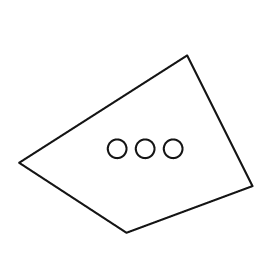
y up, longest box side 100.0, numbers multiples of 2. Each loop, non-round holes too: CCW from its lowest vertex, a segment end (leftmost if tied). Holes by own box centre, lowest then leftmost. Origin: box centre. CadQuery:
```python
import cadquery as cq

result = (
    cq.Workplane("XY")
    .moveTo(-4.0, -38.0)
    .lineTo(50.0, -18.0)
    .lineTo(22.0, 38.0)
    .lineTo(-50.0, -8.0)
    .close()
    .moveTo(-8.0, -2.0)
    .circle(4.0)
    .moveTo(4.0, -2.0)
    .circle(4.0)
    .moveTo(16.0, -2.0)
    .circle(4.0)
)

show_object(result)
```